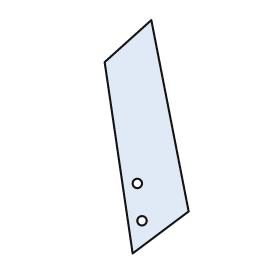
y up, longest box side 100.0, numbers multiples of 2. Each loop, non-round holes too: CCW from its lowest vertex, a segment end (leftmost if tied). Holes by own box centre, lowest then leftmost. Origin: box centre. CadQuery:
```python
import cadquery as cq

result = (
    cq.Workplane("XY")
    .moveTo(-6.0, -50.0)
    .lineTo(18.0, -32.0)
    .lineTo(2.0, 50.0)
    .lineTo(-18.0, 32.0)
    .close()
    .moveTo(-2.0, -36.0)
    .circle(2.0)
    .moveTo(-4.0, -20.0)
    .circle(2.0)
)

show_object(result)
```